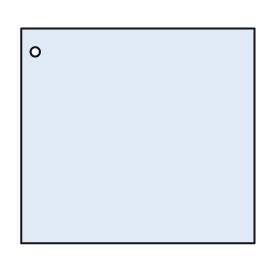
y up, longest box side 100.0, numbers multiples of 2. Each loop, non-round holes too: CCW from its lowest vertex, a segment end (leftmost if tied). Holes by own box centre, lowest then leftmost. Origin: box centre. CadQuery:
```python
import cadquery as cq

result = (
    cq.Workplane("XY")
    .moveTo(-50.0, -46.0)
    .lineTo(50.0, -46.0)
    .lineTo(50.0, 46.0)
    .lineTo(-50.0, 46.0)
    .close()
    .moveTo(-44.0, 36.0)
    .circle(2.0)
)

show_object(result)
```